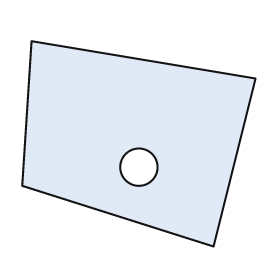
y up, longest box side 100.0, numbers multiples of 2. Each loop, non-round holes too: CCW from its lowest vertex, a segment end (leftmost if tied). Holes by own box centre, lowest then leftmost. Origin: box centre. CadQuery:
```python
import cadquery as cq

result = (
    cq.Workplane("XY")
    .moveTo(32.0, -44.0)
    .lineTo(50.0, 28.0)
    .lineTo(-46.0, 44.0)
    .lineTo(-50.0, -18.0)
    .close()
    .moveTo(0.0, -10.0)
    .circle(8.0)
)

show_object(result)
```